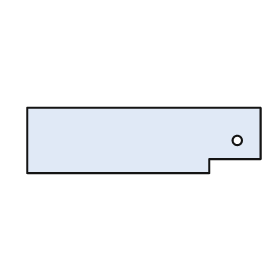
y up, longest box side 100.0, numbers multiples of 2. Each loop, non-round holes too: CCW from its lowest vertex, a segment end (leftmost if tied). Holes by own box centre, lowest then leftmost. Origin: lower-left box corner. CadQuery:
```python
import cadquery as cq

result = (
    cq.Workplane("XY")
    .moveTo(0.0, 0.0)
    .lineTo(78.0, 0.0)
    .lineTo(78.0, 6.0)
    .lineTo(100.0, 6.0)
    .lineTo(100.0, 28.0)
    .lineTo(0.0, 28.0)
    .close()
    .moveTo(90.0, 14.0)
    .circle(2.0)
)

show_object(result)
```